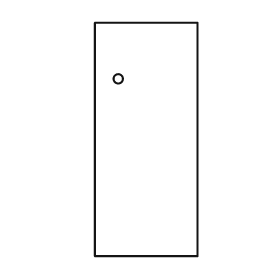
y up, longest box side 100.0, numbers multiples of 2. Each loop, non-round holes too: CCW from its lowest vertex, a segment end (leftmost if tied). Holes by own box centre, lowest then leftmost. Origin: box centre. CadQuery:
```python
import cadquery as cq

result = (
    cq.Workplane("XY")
    .moveTo(-22.0, -50.0)
    .lineTo(22.0, -50.0)
    .lineTo(22.0, 50.0)
    .lineTo(-22.0, 50.0)
    .close()
    .moveTo(-12.0, 26.0)
    .circle(2.0)
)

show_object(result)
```